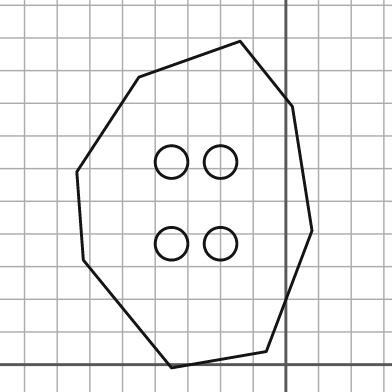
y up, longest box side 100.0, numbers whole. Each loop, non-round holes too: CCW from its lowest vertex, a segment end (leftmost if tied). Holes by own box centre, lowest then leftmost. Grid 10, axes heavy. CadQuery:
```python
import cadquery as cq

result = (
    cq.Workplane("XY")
    .moveTo(-35.0, -1.0)
    .lineTo(-6.0, 4.0)
    .lineTo(8.0, 41.0)
    .lineTo(2.0, 79.0)
    .lineTo(-14.0, 99.0)
    .lineTo(-45.0, 88.0)
    .lineTo(-64.0, 59.0)
    .lineTo(-62.0, 32.0)
    .close()
    .moveTo(-35.0, 37.0)
    .circle(5.0)
    .moveTo(-20.0, 37.0)
    .circle(5.0)
    .moveTo(-35.0, 62.0)
    .circle(5.0)
    .moveTo(-20.0, 62.0)
    .circle(5.0)
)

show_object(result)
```